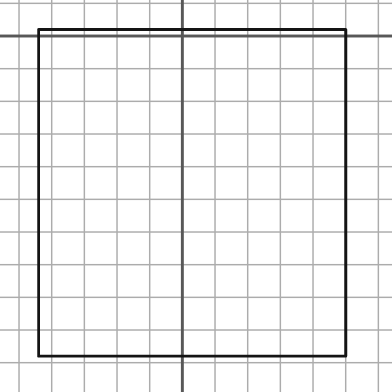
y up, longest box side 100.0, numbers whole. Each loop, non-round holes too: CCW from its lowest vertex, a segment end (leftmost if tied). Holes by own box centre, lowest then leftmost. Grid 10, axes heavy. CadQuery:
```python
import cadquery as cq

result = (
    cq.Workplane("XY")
    .moveTo(-44.0, -98.0)
    .lineTo(50.0, -98.0)
    .lineTo(50.0, 2.0)
    .lineTo(-44.0, 2.0)
    .close()
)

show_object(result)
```